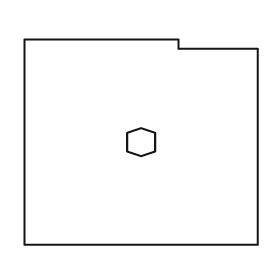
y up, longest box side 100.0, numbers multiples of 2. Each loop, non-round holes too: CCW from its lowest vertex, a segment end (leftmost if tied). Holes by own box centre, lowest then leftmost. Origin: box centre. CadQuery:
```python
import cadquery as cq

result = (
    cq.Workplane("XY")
    .moveTo(-50.0, -44.0)
    .lineTo(50.0, -44.0)
    .lineTo(50.0, 40.0)
    .lineTo(16.0, 40.0)
    .lineTo(16.0, 44.0)
    .lineTo(-50.0, 44.0)
    .close()
    .moveTo(0.0, -6.0)
    .lineTo(6.0, -4.0)
    .lineTo(6.0, 4.0)
    .lineTo(0.0, 6.0)
    .lineTo(-6.0, 4.0)
    .lineTo(-6.0, -4.0)
    .close()
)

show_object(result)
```